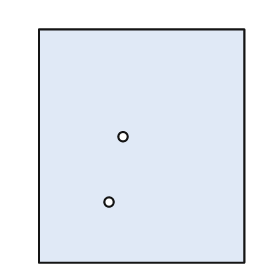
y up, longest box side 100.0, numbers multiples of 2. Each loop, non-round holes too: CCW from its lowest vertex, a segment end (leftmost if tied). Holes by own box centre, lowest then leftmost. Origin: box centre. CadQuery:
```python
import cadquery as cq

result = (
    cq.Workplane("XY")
    .moveTo(-44.0, -50.0)
    .lineTo(44.0, -50.0)
    .lineTo(44.0, 50.0)
    .lineTo(-44.0, 50.0)
    .close()
    .moveTo(-14.0, -24.0)
    .circle(2.0)
    .moveTo(-8.0, 4.0)
    .circle(2.0)
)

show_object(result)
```